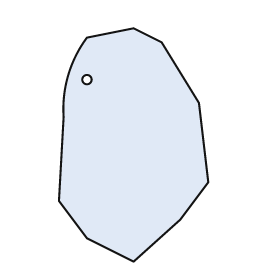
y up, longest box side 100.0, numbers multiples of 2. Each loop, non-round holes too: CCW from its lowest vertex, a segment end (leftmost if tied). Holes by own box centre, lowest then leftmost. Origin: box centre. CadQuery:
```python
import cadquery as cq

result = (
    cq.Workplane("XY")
    .moveTo(0.0, -50.0)
    .lineTo(20.0, -32.0)
    .lineTo(32.0, -16.0)
    .lineTo(28.0, 18.0)
    .lineTo(12.0, 44.0)
    .lineTo(0.0, 50.0)
    .lineTo(-20.0, 46.0)
    .threePointArc((-28.0, 30.0), (-30.0, 12.0))
    .lineTo(-32.0, -24.0)
    .lineTo(-20.0, -40.0)
    .close()
    .moveTo(-20.0, 28.0)
    .circle(2.0)
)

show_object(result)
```